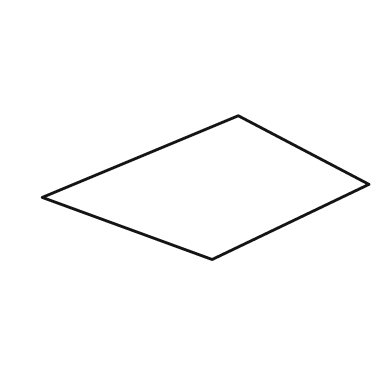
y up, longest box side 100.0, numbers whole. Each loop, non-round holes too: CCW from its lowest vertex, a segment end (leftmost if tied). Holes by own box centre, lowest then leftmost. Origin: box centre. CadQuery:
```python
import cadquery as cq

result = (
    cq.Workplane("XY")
    .moveTo(2.0, -22.0)
    .lineTo(50.0, 1.0)
    .lineTo(10.0, 22.0)
    .lineTo(-50.0, -3.0)
    .close()
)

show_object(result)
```